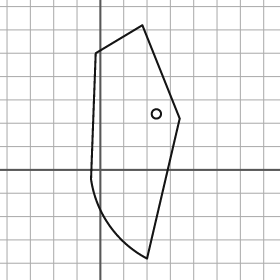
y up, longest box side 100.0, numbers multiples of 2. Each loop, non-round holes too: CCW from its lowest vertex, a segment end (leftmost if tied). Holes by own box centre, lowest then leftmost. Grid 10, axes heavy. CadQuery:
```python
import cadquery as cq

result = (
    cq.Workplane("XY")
    .moveTo(20.0, -38.0)
    .lineTo(34.0, 22.0)
    .lineTo(18.0, 62.0)
    .lineTo(-2.0, 50.0)
    .lineTo(-4.0, -4.0)
    .threePointArc((4.0, -24.0), (20.0, -38.0))
    .close()
    .moveTo(24.0, 24.0)
    .circle(2.0)
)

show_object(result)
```